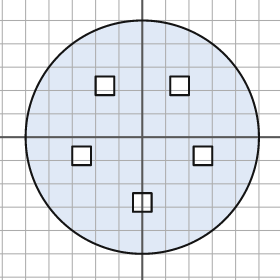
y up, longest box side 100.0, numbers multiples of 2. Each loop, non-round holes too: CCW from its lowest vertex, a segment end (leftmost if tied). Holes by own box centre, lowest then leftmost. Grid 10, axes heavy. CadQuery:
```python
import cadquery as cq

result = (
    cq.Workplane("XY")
    .moveTo(0.0, 0.0)
    .circle(50.0)
    .moveTo(-4.0, -32.0)
    .lineTo(4.0, -32.0)
    .lineTo(4.0, -24.0)
    .lineTo(-4.0, -24.0)
    .close()
    .moveTo(-30.0, -12.0)
    .lineTo(-22.0, -12.0)
    .lineTo(-22.0, -4.0)
    .lineTo(-30.0, -4.0)
    .close()
    .moveTo(22.0, -12.0)
    .lineTo(30.0, -12.0)
    .lineTo(30.0, -4.0)
    .lineTo(22.0, -4.0)
    .close()
    .moveTo(-20.0, 18.0)
    .lineTo(-12.0, 18.0)
    .lineTo(-12.0, 26.0)
    .lineTo(-20.0, 26.0)
    .close()
    .moveTo(12.0, 18.0)
    .lineTo(20.0, 18.0)
    .lineTo(20.0, 26.0)
    .lineTo(12.0, 26.0)
    .close()
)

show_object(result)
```